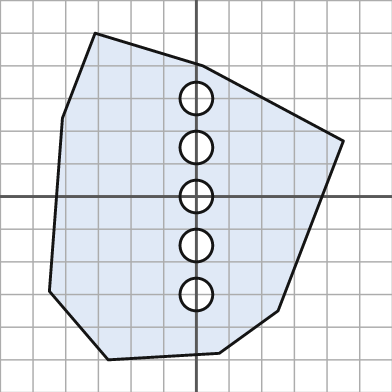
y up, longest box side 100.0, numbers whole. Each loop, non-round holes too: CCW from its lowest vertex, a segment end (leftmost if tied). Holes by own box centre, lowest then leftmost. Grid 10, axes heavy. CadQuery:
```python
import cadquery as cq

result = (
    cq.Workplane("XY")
    .moveTo(-27.0, -50.0)
    .lineTo(7.0, -48.0)
    .lineTo(25.0, -35.0)
    .lineTo(45.0, 17.0)
    .lineTo(2.0, 40.0)
    .lineTo(-31.0, 50.0)
    .lineTo(-41.0, 24.0)
    .lineTo(-45.0, -29.0)
    .close()
    .moveTo(0.0, -30.0)
    .circle(5.0)
    .moveTo(0.0, -15.0)
    .circle(5.0)
    .moveTo(0.0, 0.0)
    .circle(5.0)
    .moveTo(0.0, 15.0)
    .circle(5.0)
    .moveTo(0.0, 30.0)
    .circle(5.0)
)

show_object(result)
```